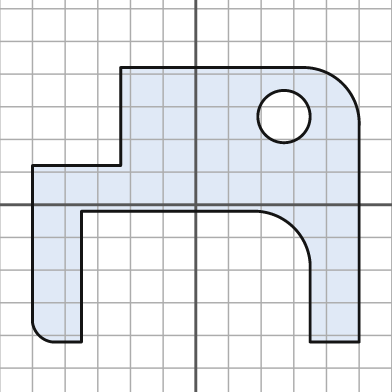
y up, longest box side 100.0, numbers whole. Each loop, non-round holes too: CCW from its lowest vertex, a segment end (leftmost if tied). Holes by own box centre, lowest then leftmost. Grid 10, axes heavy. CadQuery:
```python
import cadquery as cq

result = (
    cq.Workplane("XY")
    .moveTo(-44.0, -42.0)
    .lineTo(-35.0, -42.0)
    .lineTo(-35.0, -2.0)
    .lineTo(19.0, -2.0)
    .threePointArc((30.0, -7.0), (35.0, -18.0))
    .lineTo(35.0, -42.0)
    .lineTo(50.0, -42.0)
    .lineTo(50.0, 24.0)
    .threePointArc((45.0, 37.0), (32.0, 42.0))
    .lineTo(-23.0, 42.0)
    .lineTo(-23.0, 12.0)
    .lineTo(-50.0, 12.0)
    .lineTo(-50.0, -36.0)
    .threePointArc((-48.0, -40.0), (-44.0, -42.0))
    .close()
    .moveTo(27.0, 27.0)
    .circle(8.0)
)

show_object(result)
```